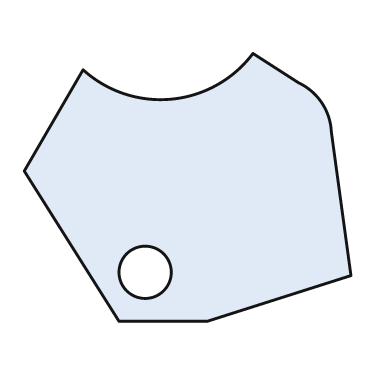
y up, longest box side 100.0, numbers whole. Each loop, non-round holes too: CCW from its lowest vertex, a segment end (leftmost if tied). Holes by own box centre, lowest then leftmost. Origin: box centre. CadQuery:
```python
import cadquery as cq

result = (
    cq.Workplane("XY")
    .moveTo(-21.0, -41.0)
    .lineTo(6.0, -41.0)
    .lineTo(50.0, -27.0)
    .lineTo(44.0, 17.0)
    .threePointArc((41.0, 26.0), (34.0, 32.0))
    .lineTo(20.0, 41.0)
    .threePointArc((-5.0, 27.0), (-32.0, 36.0))
    .lineTo(-50.0, 5.0)
    .close()
    .moveTo(-13.0, -26.0)
    .circle(8.0)
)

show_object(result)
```